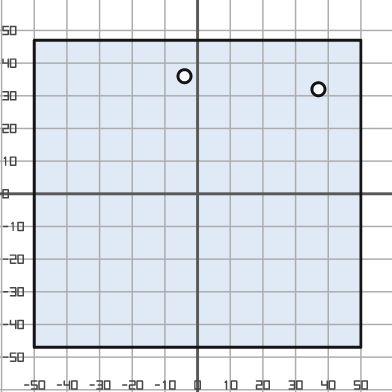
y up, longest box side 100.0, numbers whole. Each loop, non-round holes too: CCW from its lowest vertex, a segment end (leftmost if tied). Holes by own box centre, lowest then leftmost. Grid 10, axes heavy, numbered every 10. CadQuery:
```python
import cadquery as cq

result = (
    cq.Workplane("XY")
    .moveTo(-50.0, -47.0)
    .lineTo(50.0, -47.0)
    .lineTo(50.0, 47.0)
    .lineTo(-50.0, 47.0)
    .close()
    .moveTo(37.0, 32.0)
    .circle(2.0)
    .moveTo(-4.0, 36.0)
    .circle(2.0)
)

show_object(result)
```